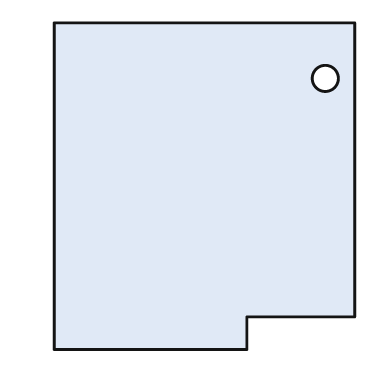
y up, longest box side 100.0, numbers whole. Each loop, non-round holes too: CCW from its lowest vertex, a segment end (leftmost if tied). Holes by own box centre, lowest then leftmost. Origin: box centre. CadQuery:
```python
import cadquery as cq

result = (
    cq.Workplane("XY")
    .moveTo(-46.0, -50.0)
    .lineTo(13.0, -50.0)
    .lineTo(13.0, -40.0)
    .lineTo(46.0, -40.0)
    .lineTo(46.0, 50.0)
    .lineTo(-46.0, 50.0)
    .close()
    .moveTo(37.0, 33.0)
    .circle(4.0)
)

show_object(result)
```